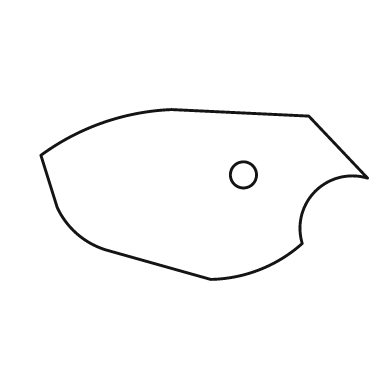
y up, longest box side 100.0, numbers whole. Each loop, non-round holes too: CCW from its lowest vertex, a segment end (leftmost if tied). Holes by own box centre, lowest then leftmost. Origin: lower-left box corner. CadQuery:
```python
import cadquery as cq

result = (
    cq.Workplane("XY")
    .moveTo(52.0, 0.0)
    .threePointArc((67.0, 3.0), (80.0, 11.0))
    .threePointArc((84.0, 27.0), (100.0, 31.0))
    .lineTo(82.0, 50.0)
    .lineTo(40.0, 52.0)
    .threePointArc((19.0, 48.0), (0.0, 38.0))
    .lineTo(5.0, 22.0)
    .threePointArc((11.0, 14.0), (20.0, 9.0))
    .close()
    .moveTo(62.0, 32.0)
    .circle(4.0)
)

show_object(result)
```